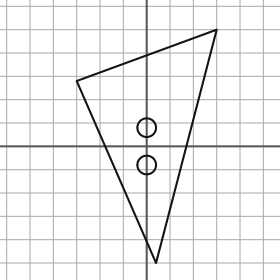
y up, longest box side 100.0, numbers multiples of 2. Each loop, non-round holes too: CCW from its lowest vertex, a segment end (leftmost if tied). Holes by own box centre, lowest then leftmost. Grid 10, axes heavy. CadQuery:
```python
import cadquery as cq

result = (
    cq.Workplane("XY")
    .moveTo(4.0, -50.0)
    .lineTo(30.0, 50.0)
    .lineTo(-30.0, 28.0)
    .close()
    .moveTo(0.0, -8.0)
    .circle(4.0)
    .moveTo(0.0, 8.0)
    .circle(4.0)
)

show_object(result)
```